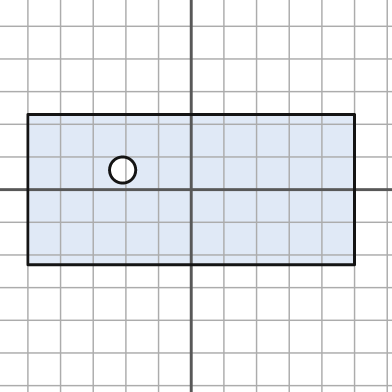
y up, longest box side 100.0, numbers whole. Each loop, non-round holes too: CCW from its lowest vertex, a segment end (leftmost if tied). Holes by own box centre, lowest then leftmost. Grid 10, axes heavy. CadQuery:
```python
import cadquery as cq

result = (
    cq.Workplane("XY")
    .moveTo(-50.0, -23.0)
    .lineTo(50.0, -23.0)
    .lineTo(50.0, 23.0)
    .lineTo(-50.0, 23.0)
    .close()
    .moveTo(-21.0, 6.0)
    .circle(4.0)
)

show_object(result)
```